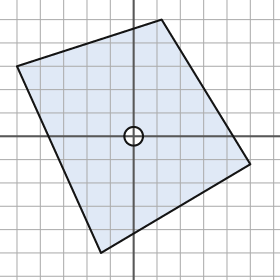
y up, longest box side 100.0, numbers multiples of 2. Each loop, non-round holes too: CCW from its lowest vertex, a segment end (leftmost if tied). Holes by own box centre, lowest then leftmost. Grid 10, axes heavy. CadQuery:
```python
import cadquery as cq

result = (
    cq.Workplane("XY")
    .moveTo(-14.0, -50.0)
    .lineTo(50.0, -12.0)
    .lineTo(12.0, 50.0)
    .lineTo(-50.0, 30.0)
    .close()
    .moveTo(0.0, 0.0)
    .circle(4.0)
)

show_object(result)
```